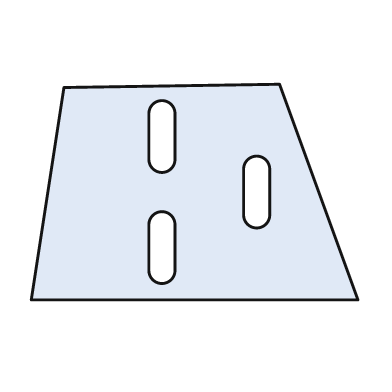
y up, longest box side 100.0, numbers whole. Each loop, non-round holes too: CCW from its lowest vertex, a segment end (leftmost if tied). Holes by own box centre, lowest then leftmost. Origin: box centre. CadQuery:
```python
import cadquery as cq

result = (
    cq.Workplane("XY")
    .moveTo(-50.0, -33.0)
    .lineTo(50.0, -33.0)
    .lineTo(26.0, 33.0)
    .lineTo(-40.0, 32.0)
    .close()
    .moveTo(-14.0, -24.0)
    .threePointArc((-10.0, -28.0), (-6.0, -24.0))
    .lineTo(-6.0, -10.0)
    .threePointArc((-10.0, -6.0), (-14.0, -10.0))
    .close()
    .moveTo(15.0, -7.0)
    .threePointArc((19.0, -11.0), (23.0, -7.0))
    .lineTo(23.0, 7.0)
    .threePointArc((19.0, 11.0), (15.0, 7.0))
    .close()
    .moveTo(-14.0, 10.0)
    .threePointArc((-10.0, 6.0), (-6.0, 10.0))
    .lineTo(-6.0, 24.0)
    .threePointArc((-10.0, 28.0), (-14.0, 24.0))
    .close()
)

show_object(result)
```